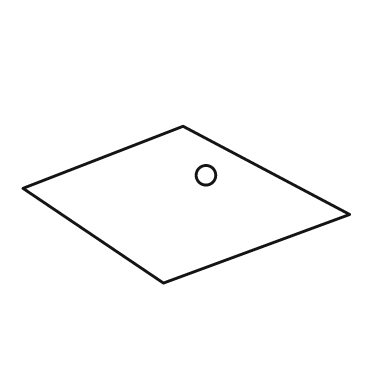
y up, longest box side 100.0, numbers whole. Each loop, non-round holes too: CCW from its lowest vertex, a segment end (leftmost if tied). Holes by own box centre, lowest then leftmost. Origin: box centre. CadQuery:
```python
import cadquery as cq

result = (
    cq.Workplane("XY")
    .moveTo(-7.0, -24.0)
    .lineTo(50.0, -3.0)
    .lineTo(-1.0, 24.0)
    .lineTo(-50.0, 5.0)
    .close()
    .moveTo(6.0, 9.0)
    .circle(3.0)
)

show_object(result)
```